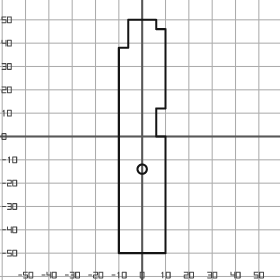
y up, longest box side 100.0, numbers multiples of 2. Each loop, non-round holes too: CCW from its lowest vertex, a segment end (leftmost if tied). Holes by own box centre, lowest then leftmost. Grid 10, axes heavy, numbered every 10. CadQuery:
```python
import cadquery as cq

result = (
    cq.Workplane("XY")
    .moveTo(-10.0, -50.0)
    .lineTo(10.0, -50.0)
    .lineTo(10.0, 0.0)
    .lineTo(6.0, 0.0)
    .lineTo(6.0, 12.0)
    .lineTo(10.0, 12.0)
    .lineTo(10.0, 46.0)
    .lineTo(6.0, 46.0)
    .lineTo(6.0, 50.0)
    .lineTo(-6.0, 50.0)
    .lineTo(-6.0, 38.0)
    .lineTo(-10.0, 38.0)
    .close()
    .moveTo(0.0, -14.0)
    .circle(2.0)
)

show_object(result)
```